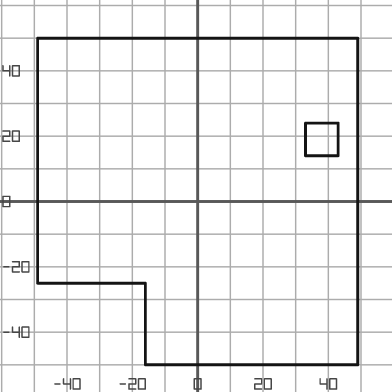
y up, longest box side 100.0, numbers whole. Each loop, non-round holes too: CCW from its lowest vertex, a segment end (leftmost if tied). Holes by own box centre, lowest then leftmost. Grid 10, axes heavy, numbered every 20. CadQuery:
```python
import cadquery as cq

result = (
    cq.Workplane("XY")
    .moveTo(-16.0, -50.0)
    .lineTo(49.0, -50.0)
    .lineTo(49.0, 50.0)
    .lineTo(-49.0, 50.0)
    .lineTo(-49.0, -25.0)
    .lineTo(-16.0, -25.0)
    .close()
    .moveTo(33.0, 14.0)
    .lineTo(43.0, 14.0)
    .lineTo(43.0, 24.0)
    .lineTo(33.0, 24.0)
    .close()
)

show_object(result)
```